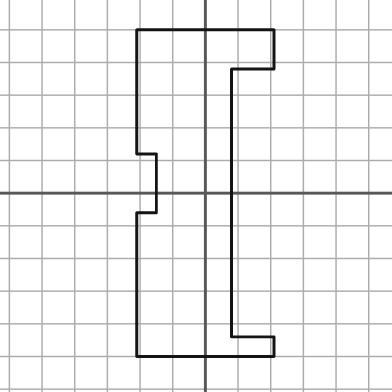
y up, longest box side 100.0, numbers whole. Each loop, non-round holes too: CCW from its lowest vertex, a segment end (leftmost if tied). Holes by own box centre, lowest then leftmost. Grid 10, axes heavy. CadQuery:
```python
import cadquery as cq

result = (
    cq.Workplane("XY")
    .moveTo(-21.0, -50.0)
    .lineTo(21.0, -50.0)
    .lineTo(21.0, -44.0)
    .lineTo(8.0, -44.0)
    .lineTo(8.0, 38.0)
    .lineTo(21.0, 38.0)
    .lineTo(21.0, 50.0)
    .lineTo(-21.0, 50.0)
    .lineTo(-21.0, 12.0)
    .lineTo(-15.0, 12.0)
    .lineTo(-15.0, -6.0)
    .lineTo(-21.0, -6.0)
    .close()
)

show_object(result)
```